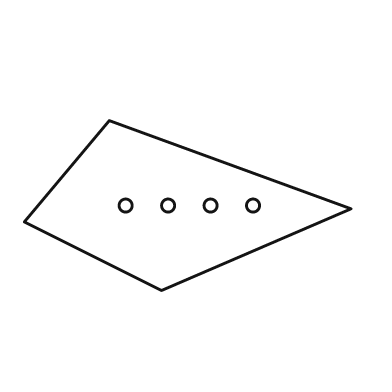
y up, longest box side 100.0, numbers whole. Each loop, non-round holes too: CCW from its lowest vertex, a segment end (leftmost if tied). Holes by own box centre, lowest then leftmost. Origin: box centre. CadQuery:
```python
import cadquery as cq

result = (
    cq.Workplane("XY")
    .moveTo(-8.0, -26.0)
    .lineTo(50.0, -1.0)
    .lineTo(-24.0, 26.0)
    .lineTo(-50.0, -5.0)
    .close()
    .moveTo(-19.0, 0.0)
    .circle(2.0)
    .moveTo(-6.0, 0.0)
    .circle(2.0)
    .moveTo(7.0, 0.0)
    .circle(2.0)
    .moveTo(20.0, 0.0)
    .circle(2.0)
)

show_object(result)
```